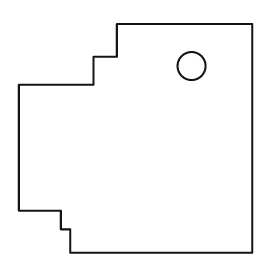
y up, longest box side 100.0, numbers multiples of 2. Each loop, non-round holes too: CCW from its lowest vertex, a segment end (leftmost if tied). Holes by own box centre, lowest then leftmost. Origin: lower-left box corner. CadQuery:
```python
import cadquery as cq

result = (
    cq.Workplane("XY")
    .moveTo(22.0, 0.0)
    .lineTo(100.0, 0.0)
    .lineTo(100.0, 98.0)
    .lineTo(42.0, 98.0)
    .lineTo(42.0, 84.0)
    .lineTo(32.0, 84.0)
    .lineTo(32.0, 72.0)
    .lineTo(0.0, 72.0)
    .lineTo(0.0, 18.0)
    .lineTo(18.0, 18.0)
    .lineTo(18.0, 10.0)
    .lineTo(22.0, 10.0)
    .close()
    .moveTo(74.0, 80.0)
    .circle(6.0)
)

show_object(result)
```